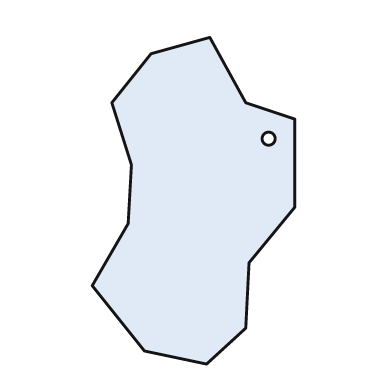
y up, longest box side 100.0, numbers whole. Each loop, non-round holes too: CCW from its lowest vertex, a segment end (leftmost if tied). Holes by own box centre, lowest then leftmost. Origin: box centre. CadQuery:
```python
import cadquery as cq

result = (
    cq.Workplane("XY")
    .moveTo(4.0, -50.0)
    .lineTo(16.0, -39.0)
    .lineTo(17.0, -19.0)
    .lineTo(31.0, -2.0)
    .lineTo(31.0, 25.0)
    .lineTo(16.0, 30.0)
    .lineTo(5.0, 50.0)
    .lineTo(-13.0, 45.0)
    .lineTo(-25.0, 30.0)
    .lineTo(-19.0, 11.0)
    .lineTo(-20.0, -7.0)
    .lineTo(-31.0, -26.0)
    .lineTo(-15.0, -46.0)
    .close()
    .moveTo(23.0, 19.0)
    .circle(2.0)
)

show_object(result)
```